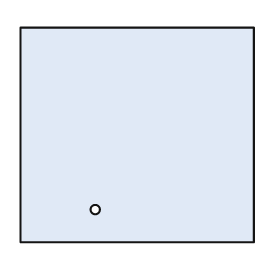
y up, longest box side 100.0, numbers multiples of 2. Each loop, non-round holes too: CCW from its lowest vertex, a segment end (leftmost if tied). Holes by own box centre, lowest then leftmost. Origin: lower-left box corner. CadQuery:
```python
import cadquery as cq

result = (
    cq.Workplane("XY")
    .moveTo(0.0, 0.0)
    .lineTo(100.0, 0.0)
    .lineTo(100.0, 92.0)
    .lineTo(0.0, 92.0)
    .close()
    .moveTo(32.0, 14.0)
    .circle(2.0)
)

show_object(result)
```